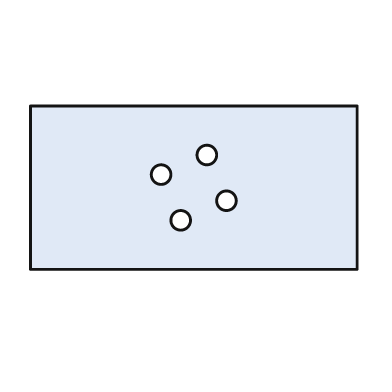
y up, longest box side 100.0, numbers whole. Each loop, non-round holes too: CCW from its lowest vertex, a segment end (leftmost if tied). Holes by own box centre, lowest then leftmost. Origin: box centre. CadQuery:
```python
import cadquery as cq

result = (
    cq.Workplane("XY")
    .moveTo(-50.0, -25.0)
    .lineTo(50.0, -25.0)
    .lineTo(50.0, 25.0)
    .lineTo(-50.0, 25.0)
    .close()
    .moveTo(-4.0, -10.0)
    .circle(3.0)
    .moveTo(10.0, -4.0)
    .circle(3.0)
    .moveTo(-10.0, 4.0)
    .circle(3.0)
    .moveTo(4.0, 10.0)
    .circle(3.0)
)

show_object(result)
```